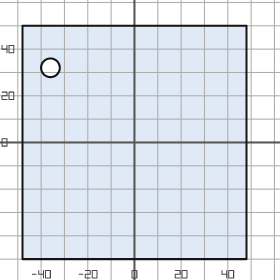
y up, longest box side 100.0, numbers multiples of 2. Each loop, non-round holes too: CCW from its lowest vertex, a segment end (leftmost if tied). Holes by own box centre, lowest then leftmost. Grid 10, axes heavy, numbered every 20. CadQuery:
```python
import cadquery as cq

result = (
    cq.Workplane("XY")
    .moveTo(-48.0, -50.0)
    .lineTo(48.0, -50.0)
    .lineTo(48.0, 50.0)
    .lineTo(-48.0, 50.0)
    .close()
    .moveTo(-36.0, 32.0)
    .circle(4.0)
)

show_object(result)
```